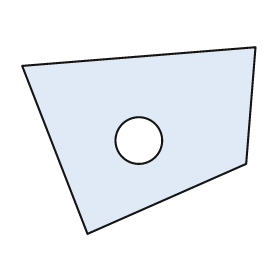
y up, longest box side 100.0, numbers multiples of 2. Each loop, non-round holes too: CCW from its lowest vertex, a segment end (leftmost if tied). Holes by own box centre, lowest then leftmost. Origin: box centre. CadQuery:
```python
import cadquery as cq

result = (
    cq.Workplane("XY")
    .moveTo(-22.0, -40.0)
    .lineTo(46.0, -10.0)
    .lineTo(50.0, 40.0)
    .lineTo(-50.0, 32.0)
    .close()
    .moveTo(0.0, 0.0)
    .circle(10.0)
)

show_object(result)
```